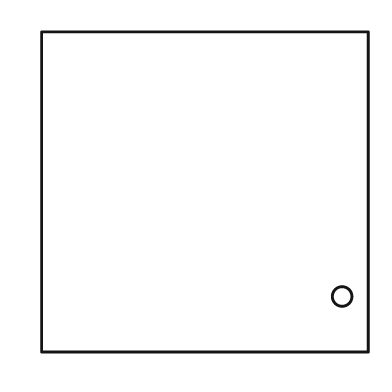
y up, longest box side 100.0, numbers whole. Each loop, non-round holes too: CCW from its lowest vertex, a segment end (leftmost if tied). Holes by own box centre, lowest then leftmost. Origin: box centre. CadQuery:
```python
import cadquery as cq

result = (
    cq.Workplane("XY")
    .moveTo(-50.0, -49.0)
    .lineTo(50.0, -49.0)
    .lineTo(50.0, 49.0)
    .lineTo(-50.0, 49.0)
    .close()
    .moveTo(42.0, -32.0)
    .circle(3.0)
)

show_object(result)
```